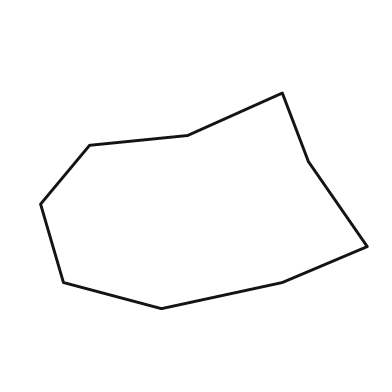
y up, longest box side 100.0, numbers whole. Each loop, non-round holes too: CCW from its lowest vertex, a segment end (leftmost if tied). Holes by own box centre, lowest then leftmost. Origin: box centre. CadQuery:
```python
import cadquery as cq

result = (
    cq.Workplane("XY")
    .moveTo(-13.0, -33.0)
    .lineTo(24.0, -25.0)
    .lineTo(50.0, -14.0)
    .lineTo(32.0, 12.0)
    .lineTo(24.0, 33.0)
    .lineTo(-5.0, 20.0)
    .lineTo(-35.0, 17.0)
    .lineTo(-50.0, -1.0)
    .lineTo(-43.0, -25.0)
    .close()
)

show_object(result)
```